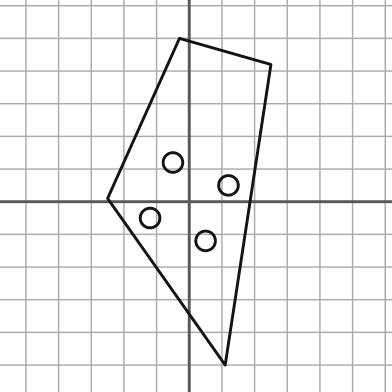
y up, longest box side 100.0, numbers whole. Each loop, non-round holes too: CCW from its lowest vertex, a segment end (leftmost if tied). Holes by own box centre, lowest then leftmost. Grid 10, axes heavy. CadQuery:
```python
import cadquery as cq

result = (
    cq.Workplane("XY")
    .moveTo(11.0, -50.0)
    .lineTo(25.0, 42.0)
    .lineTo(-3.0, 50.0)
    .lineTo(-25.0, 1.0)
    .close()
    .moveTo(5.0, -12.0)
    .circle(3.0)
    .moveTo(-12.0, -5.0)
    .circle(3.0)
    .moveTo(12.0, 5.0)
    .circle(3.0)
    .moveTo(-5.0, 12.0)
    .circle(3.0)
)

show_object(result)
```